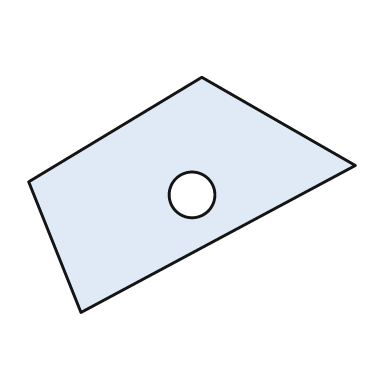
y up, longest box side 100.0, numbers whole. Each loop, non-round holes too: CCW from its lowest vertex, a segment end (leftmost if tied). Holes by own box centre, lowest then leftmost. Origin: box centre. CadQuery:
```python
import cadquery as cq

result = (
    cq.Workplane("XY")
    .moveTo(-34.0, -36.0)
    .lineTo(50.0, 9.0)
    .lineTo(3.0, 36.0)
    .lineTo(-50.0, 4.0)
    .close()
    .moveTo(0.0, 0.0)
    .circle(7.0)
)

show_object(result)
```